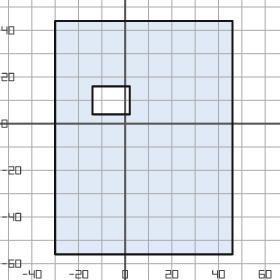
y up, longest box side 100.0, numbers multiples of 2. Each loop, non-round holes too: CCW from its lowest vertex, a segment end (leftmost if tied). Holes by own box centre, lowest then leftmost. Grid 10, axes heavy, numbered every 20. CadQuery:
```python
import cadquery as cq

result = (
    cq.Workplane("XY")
    .moveTo(-30.0, -56.0)
    .lineTo(46.0, -56.0)
    .lineTo(46.0, 44.0)
    .lineTo(-30.0, 44.0)
    .close()
    .moveTo(-14.0, 4.0)
    .lineTo(2.0, 4.0)
    .lineTo(2.0, 16.0)
    .lineTo(-14.0, 16.0)
    .close()
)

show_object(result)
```